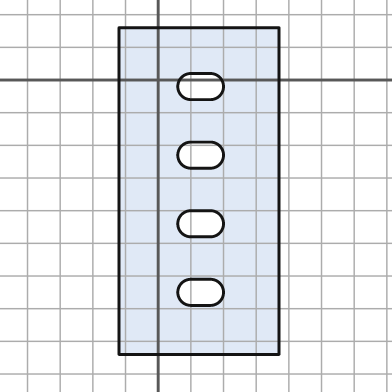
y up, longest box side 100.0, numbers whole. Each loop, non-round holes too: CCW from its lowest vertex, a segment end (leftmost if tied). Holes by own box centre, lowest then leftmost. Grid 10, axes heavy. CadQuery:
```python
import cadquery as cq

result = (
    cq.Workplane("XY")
    .moveTo(-12.0, -84.0)
    .lineTo(37.0, -84.0)
    .lineTo(37.0, 16.0)
    .lineTo(-12.0, 16.0)
    .close()
    .moveTo(10.0, -69.0)
    .lineTo(16.0, -69.0)
    .threePointArc((20.0, -65.0), (16.0, -61.0))
    .lineTo(10.0, -61.0)
    .threePointArc((6.0, -65.0), (10.0, -69.0))
    .close()
    .moveTo(10.0, -48.0)
    .lineTo(16.0, -48.0)
    .threePointArc((20.0, -44.0), (16.0, -40.0))
    .lineTo(10.0, -40.0)
    .threePointArc((6.0, -44.0), (10.0, -48.0))
    .close()
    .moveTo(10.0, -27.0)
    .lineTo(16.0, -27.0)
    .threePointArc((20.0, -23.0), (16.0, -19.0))
    .lineTo(10.0, -19.0)
    .threePointArc((6.0, -23.0), (10.0, -27.0))
    .close()
    .moveTo(10.0, -6.0)
    .lineTo(16.0, -6.0)
    .threePointArc((20.0, -2.0), (16.0, 2.0))
    .lineTo(10.0, 2.0)
    .threePointArc((6.0, -2.0), (10.0, -6.0))
    .close()
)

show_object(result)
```